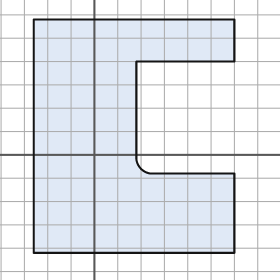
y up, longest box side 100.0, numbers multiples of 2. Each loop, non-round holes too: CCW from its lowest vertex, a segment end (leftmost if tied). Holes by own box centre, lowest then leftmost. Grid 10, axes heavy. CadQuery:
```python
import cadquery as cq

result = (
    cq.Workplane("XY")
    .moveTo(-26.0, -42.0)
    .lineTo(60.0, -42.0)
    .lineTo(60.0, -8.0)
    .lineTo(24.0, -8.0)
    .threePointArc((20.0, -6.0), (18.0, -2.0))
    .lineTo(18.0, 40.0)
    .lineTo(60.0, 40.0)
    .lineTo(60.0, 58.0)
    .lineTo(-26.0, 58.0)
    .close()
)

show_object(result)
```